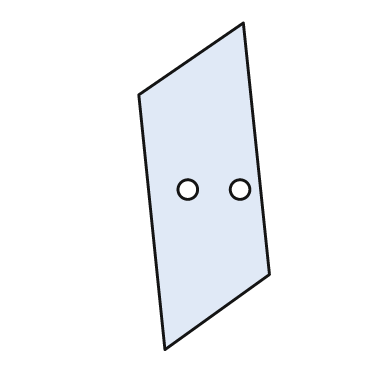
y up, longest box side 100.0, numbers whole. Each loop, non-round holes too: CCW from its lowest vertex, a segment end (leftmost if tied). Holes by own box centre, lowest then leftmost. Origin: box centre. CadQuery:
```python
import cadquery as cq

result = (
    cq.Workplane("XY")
    .moveTo(-12.0, -50.0)
    .lineTo(20.0, -27.0)
    .lineTo(12.0, 50.0)
    .lineTo(-20.0, 28.0)
    .close()
    .moveTo(-5.0, -1.0)
    .circle(3.0)
    .moveTo(11.0, -1.0)
    .circle(3.0)
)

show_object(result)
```